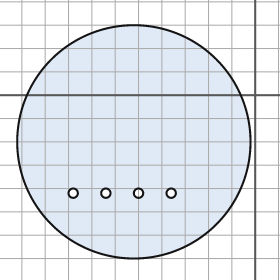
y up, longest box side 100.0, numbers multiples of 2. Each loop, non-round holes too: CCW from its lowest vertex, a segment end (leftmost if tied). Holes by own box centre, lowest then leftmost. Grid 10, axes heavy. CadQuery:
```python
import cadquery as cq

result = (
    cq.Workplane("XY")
    .moveTo(-52.0, -20.0)
    .circle(50.0)
    .moveTo(-78.0, -42.0)
    .circle(2.0)
    .moveTo(-64.0, -42.0)
    .circle(2.0)
    .moveTo(-50.0, -42.0)
    .circle(2.0)
    .moveTo(-36.0, -42.0)
    .circle(2.0)
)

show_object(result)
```